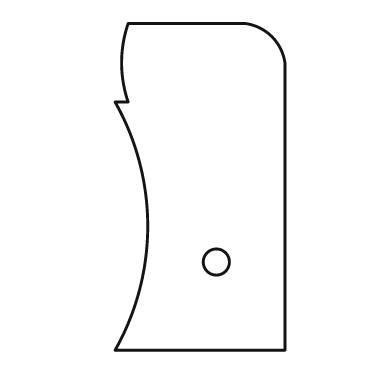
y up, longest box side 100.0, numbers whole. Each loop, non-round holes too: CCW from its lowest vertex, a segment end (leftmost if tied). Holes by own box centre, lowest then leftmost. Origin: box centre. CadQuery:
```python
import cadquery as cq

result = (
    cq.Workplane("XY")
    .moveTo(-26.0, -50.0)
    .lineTo(26.0, -50.0)
    .lineTo(26.0, 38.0)
    .threePointArc((22.0, 46.0), (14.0, 50.0))
    .lineTo(-22.0, 50.0)
    .threePointArc((-24.0, 38.0), (-22.0, 26.0))
    .lineTo(-26.0, 26.0)
    .threePointArc((-16.0, -12.0), (-26.0, -50.0))
    .close()
    .moveTo(5.0, -23.0)
    .circle(4.0)
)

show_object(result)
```